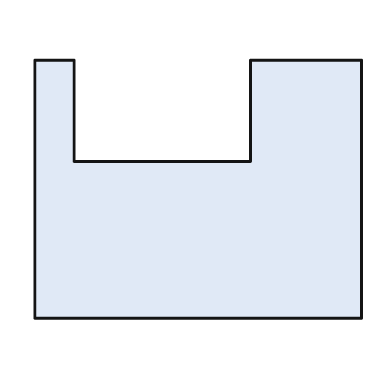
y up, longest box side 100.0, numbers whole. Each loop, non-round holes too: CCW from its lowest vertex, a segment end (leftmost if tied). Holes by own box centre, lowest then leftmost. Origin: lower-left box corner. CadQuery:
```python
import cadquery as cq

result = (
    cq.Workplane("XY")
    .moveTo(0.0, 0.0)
    .lineTo(100.0, 0.0)
    .lineTo(100.0, 79.0)
    .lineTo(66.0, 79.0)
    .lineTo(66.0, 48.0)
    .lineTo(12.0, 48.0)
    .lineTo(12.0, 79.0)
    .lineTo(0.0, 79.0)
    .close()
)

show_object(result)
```